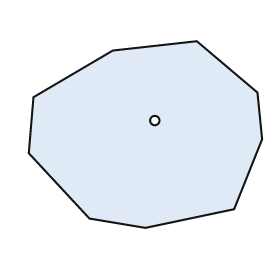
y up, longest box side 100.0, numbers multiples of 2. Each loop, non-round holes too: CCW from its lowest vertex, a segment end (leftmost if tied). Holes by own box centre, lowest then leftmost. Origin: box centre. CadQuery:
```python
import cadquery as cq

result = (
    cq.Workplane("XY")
    .moveTo(0.0, -40.0)
    .lineTo(38.0, -32.0)
    .lineTo(50.0, -2.0)
    .lineTo(48.0, 18.0)
    .lineTo(22.0, 40.0)
    .lineTo(-14.0, 36.0)
    .lineTo(-48.0, 16.0)
    .lineTo(-50.0, -8.0)
    .lineTo(-24.0, -36.0)
    .close()
    .moveTo(4.0, 6.0)
    .circle(2.0)
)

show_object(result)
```